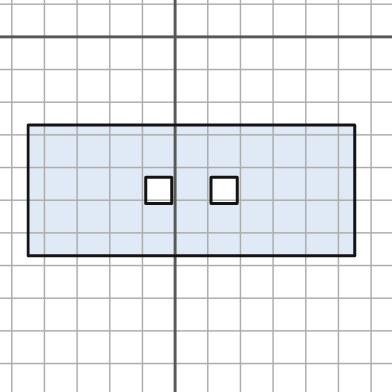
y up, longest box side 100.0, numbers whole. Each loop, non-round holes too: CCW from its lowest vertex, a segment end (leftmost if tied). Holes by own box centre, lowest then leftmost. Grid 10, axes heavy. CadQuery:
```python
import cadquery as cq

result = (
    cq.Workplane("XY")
    .moveTo(-45.0, -67.0)
    .lineTo(55.0, -67.0)
    .lineTo(55.0, -27.0)
    .lineTo(-45.0, -27.0)
    .close()
    .moveTo(-9.0, -51.0)
    .lineTo(-1.0, -51.0)
    .lineTo(-1.0, -43.0)
    .lineTo(-9.0, -43.0)
    .close()
    .moveTo(11.0, -51.0)
    .lineTo(19.0, -51.0)
    .lineTo(19.0, -43.0)
    .lineTo(11.0, -43.0)
    .close()
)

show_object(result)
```